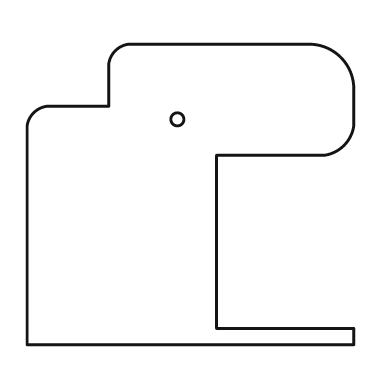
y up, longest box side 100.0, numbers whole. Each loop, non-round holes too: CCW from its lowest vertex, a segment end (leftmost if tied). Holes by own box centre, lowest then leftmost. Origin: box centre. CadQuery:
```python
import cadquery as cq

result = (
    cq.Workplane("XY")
    .moveTo(-50.0, -46.0)
    .lineTo(50.0, -46.0)
    .lineTo(50.0, -41.0)
    .lineTo(8.0, -41.0)
    .lineTo(8.0, 12.0)
    .lineTo(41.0, 12.0)
    .threePointArc((47.0, 15.0), (50.0, 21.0))
    .lineTo(50.0, 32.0)
    .threePointArc((46.0, 42.0), (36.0, 46.0))
    .lineTo(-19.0, 46.0)
    .threePointArc((-23.0, 44.0), (-25.0, 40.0))
    .lineTo(-25.0, 27.0)
    .lineTo(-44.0, 27.0)
    .threePointArc((-48.0, 25.0), (-50.0, 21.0))
    .close()
    .moveTo(-4.0, 23.0)
    .circle(2.0)
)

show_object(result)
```